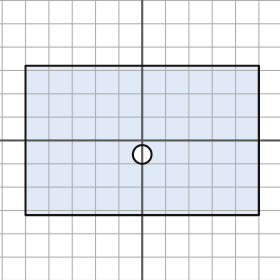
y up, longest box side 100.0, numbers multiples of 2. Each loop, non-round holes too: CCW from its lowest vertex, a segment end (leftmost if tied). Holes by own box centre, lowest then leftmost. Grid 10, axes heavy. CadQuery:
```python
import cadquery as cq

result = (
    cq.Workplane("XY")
    .moveTo(-50.0, -32.0)
    .lineTo(50.0, -32.0)
    .lineTo(50.0, 32.0)
    .lineTo(-50.0, 32.0)
    .close()
    .moveTo(0.0, -6.0)
    .circle(4.0)
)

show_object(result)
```